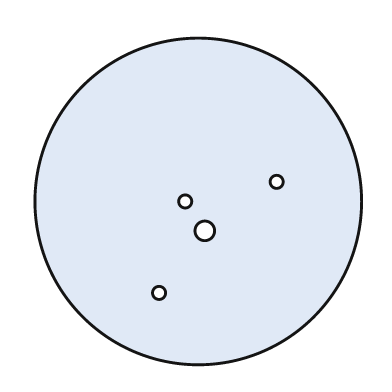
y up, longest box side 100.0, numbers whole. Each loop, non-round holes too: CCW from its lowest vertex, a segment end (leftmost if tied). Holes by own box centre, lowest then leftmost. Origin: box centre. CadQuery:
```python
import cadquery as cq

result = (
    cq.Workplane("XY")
    .moveTo(0.0, 0.0)
    .circle(50.0)
    .moveTo(-12.0, -28.0)
    .circle(2.0)
    .moveTo(2.0, -9.0)
    .circle(3.0)
    .moveTo(-4.0, 0.0)
    .circle(2.0)
    .moveTo(24.0, 6.0)
    .circle(2.0)
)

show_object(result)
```